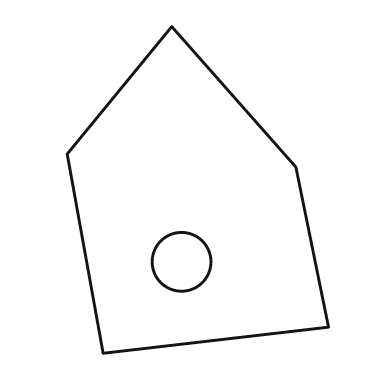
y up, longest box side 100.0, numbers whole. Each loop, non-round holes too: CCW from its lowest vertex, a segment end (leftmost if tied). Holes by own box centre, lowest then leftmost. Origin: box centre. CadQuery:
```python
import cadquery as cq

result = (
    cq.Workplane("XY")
    .moveTo(-29.0, -50.0)
    .lineTo(40.0, -42.0)
    .lineTo(30.0, 7.0)
    .lineTo(-8.0, 50.0)
    .lineTo(-40.0, 11.0)
    .close()
    .moveTo(-5.0, -22.0)
    .circle(9.0)
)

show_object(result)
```